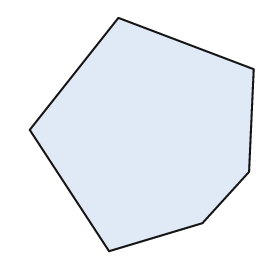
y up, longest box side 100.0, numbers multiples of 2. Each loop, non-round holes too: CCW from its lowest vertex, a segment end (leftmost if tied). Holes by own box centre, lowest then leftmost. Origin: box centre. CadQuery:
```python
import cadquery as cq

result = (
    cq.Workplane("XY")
    .moveTo(-14.0, -50.0)
    .lineTo(26.0, -38.0)
    .lineTo(46.0, -16.0)
    .lineTo(48.0, 28.0)
    .lineTo(-10.0, 50.0)
    .lineTo(-48.0, 2.0)
    .close()
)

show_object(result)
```